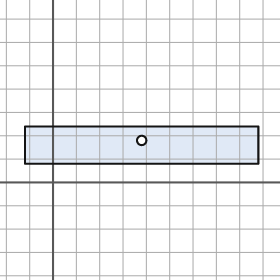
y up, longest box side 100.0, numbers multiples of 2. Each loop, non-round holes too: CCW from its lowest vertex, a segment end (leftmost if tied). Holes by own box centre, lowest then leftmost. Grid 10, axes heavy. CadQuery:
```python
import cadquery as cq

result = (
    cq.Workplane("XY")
    .moveTo(-12.0, 8.0)
    .lineTo(88.0, 8.0)
    .lineTo(88.0, 24.0)
    .lineTo(-12.0, 24.0)
    .close()
    .moveTo(38.0, 18.0)
    .circle(2.0)
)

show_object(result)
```